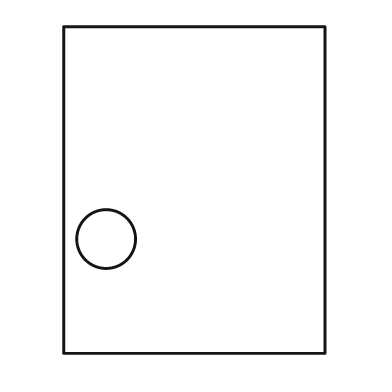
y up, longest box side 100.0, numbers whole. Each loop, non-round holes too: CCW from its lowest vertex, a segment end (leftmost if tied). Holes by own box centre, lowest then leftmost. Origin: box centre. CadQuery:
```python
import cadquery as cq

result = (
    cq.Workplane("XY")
    .moveTo(-40.0, -50.0)
    .lineTo(40.0, -50.0)
    .lineTo(40.0, 50.0)
    .lineTo(-40.0, 50.0)
    .close()
    .moveTo(-27.0, -15.0)
    .circle(9.0)
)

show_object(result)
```